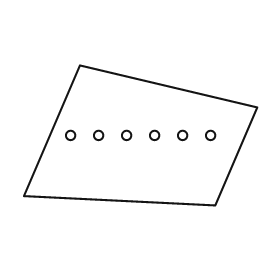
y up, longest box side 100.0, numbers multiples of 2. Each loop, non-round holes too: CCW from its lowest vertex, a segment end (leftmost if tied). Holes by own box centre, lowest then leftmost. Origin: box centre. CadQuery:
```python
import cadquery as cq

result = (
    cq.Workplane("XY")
    .moveTo(32.0, -30.0)
    .lineTo(50.0, 12.0)
    .lineTo(-26.0, 30.0)
    .lineTo(-50.0, -26.0)
    .close()
    .moveTo(-30.0, 0.0)
    .circle(2.0)
    .moveTo(-18.0, 0.0)
    .circle(2.0)
    .moveTo(-6.0, 0.0)
    .circle(2.0)
    .moveTo(6.0, 0.0)
    .circle(2.0)
    .moveTo(18.0, 0.0)
    .circle(2.0)
    .moveTo(30.0, 0.0)
    .circle(2.0)
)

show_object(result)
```